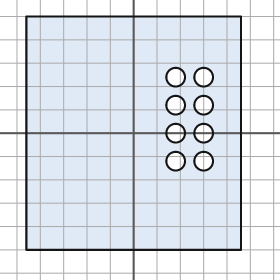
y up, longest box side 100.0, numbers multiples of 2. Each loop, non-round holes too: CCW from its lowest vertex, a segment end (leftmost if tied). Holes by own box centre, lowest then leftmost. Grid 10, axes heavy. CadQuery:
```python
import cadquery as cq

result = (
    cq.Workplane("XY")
    .moveTo(-46.0, -50.0)
    .lineTo(46.0, -50.0)
    .lineTo(46.0, 50.0)
    .lineTo(-46.0, 50.0)
    .close()
    .moveTo(18.0, -12.0)
    .circle(4.0)
    .moveTo(30.0, -12.0)
    .circle(4.0)
    .moveTo(18.0, 0.0)
    .circle(4.0)
    .moveTo(30.0, 0.0)
    .circle(4.0)
    .moveTo(18.0, 12.0)
    .circle(4.0)
    .moveTo(30.0, 12.0)
    .circle(4.0)
    .moveTo(18.0, 24.0)
    .circle(4.0)
    .moveTo(30.0, 24.0)
    .circle(4.0)
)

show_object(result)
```